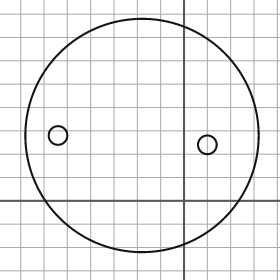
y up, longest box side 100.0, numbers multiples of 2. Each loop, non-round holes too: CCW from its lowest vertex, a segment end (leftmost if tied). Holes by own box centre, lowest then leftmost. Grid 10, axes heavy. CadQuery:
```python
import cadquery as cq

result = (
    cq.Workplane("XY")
    .moveTo(-18.0, 28.0)
    .circle(50.0)
    .moveTo(10.0, 24.0)
    .circle(4.0)
    .moveTo(-54.0, 28.0)
    .circle(4.0)
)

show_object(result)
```